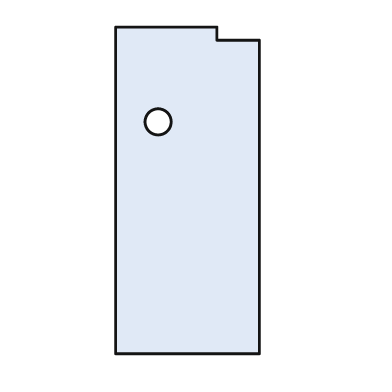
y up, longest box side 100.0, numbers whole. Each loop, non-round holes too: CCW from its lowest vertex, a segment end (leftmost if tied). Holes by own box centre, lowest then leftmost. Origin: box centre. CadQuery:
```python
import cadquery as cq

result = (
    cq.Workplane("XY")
    .moveTo(-22.0, -50.0)
    .lineTo(22.0, -50.0)
    .lineTo(22.0, 46.0)
    .lineTo(9.0, 46.0)
    .lineTo(9.0, 50.0)
    .lineTo(-22.0, 50.0)
    .close()
    .moveTo(-9.0, 21.0)
    .circle(4.0)
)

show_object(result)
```